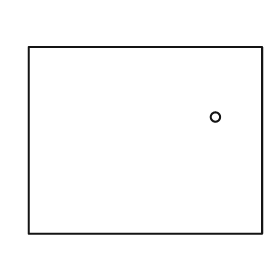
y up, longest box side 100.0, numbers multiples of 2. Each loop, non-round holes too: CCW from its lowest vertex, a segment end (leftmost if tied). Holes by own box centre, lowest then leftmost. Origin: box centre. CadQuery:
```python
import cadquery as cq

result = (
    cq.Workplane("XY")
    .moveTo(-50.0, -40.0)
    .lineTo(50.0, -40.0)
    .lineTo(50.0, 40.0)
    .lineTo(-50.0, 40.0)
    .close()
    .moveTo(30.0, 10.0)
    .circle(2.0)
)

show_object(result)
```